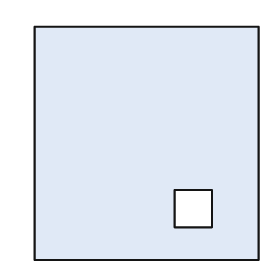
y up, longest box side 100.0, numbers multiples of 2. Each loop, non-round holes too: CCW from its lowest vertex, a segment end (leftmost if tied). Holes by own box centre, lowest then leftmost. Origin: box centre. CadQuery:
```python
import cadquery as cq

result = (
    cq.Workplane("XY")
    .moveTo(-48.0, -50.0)
    .lineTo(48.0, -50.0)
    .lineTo(48.0, 50.0)
    .lineTo(-48.0, 50.0)
    .close()
    .moveTo(12.0, -36.0)
    .lineTo(28.0, -36.0)
    .lineTo(28.0, -20.0)
    .lineTo(12.0, -20.0)
    .close()
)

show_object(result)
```